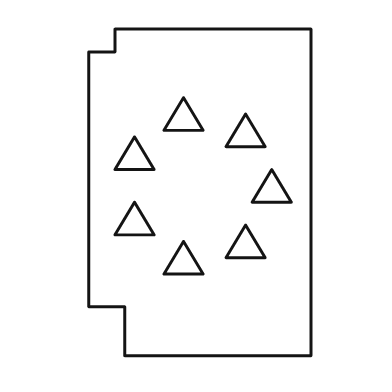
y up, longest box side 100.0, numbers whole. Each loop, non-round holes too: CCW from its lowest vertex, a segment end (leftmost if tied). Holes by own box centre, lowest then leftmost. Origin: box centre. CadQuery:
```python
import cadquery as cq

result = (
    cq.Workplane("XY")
    .moveTo(-23.0, -50.0)
    .lineTo(34.0, -50.0)
    .lineTo(34.0, 50.0)
    .lineTo(-26.0, 50.0)
    .lineTo(-26.0, 43.0)
    .lineTo(-34.0, 43.0)
    .lineTo(-34.0, -35.0)
    .lineTo(-23.0, -35.0)
    .close()
    .moveTo(-11.0, -25.0)
    .lineTo(1.0, -25.0)
    .lineTo(-5.0, -15.0)
    .close()
    .moveTo(8.0, -20.0)
    .lineTo(20.0, -20.0)
    .lineTo(14.0, -10.0)
    .close()
    .moveTo(-26.0, -13.0)
    .lineTo(-14.0, -13.0)
    .lineTo(-20.0, -3.0)
    .close()
    .moveTo(16.0, -3.0)
    .lineTo(28.0, -3.0)
    .lineTo(22.0, 7.0)
    .close()
    .moveTo(-26.0, 7.0)
    .lineTo(-14.0, 7.0)
    .lineTo(-20.0, 17.0)
    .close()
    .moveTo(8.0, 14.0)
    .lineTo(20.0, 14.0)
    .lineTo(14.0, 24.0)
    .close()
    .moveTo(-11.0, 19.0)
    .lineTo(1.0, 19.0)
    .lineTo(-5.0, 29.0)
    .close()
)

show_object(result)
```